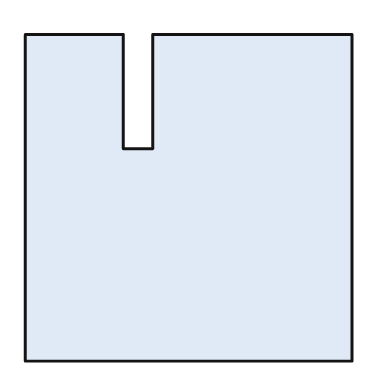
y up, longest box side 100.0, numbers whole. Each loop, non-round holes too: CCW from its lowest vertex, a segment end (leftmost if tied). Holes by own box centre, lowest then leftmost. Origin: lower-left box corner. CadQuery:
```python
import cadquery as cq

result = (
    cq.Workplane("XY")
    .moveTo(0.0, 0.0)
    .lineTo(100.0, 0.0)
    .lineTo(100.0, 100.0)
    .lineTo(39.0, 100.0)
    .lineTo(39.0, 65.0)
    .lineTo(30.0, 65.0)
    .lineTo(30.0, 100.0)
    .lineTo(0.0, 100.0)
    .close()
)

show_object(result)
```